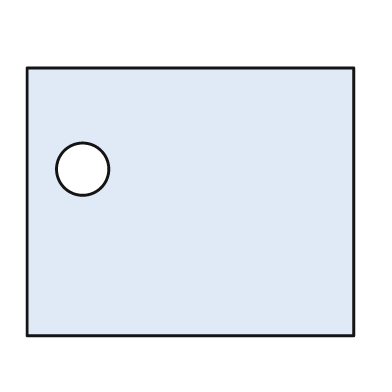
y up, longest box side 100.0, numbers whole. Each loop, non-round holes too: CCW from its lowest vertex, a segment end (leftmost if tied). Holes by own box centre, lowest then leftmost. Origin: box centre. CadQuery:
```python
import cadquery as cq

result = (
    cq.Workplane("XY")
    .moveTo(-50.0, -41.0)
    .lineTo(50.0, -41.0)
    .lineTo(50.0, 41.0)
    .lineTo(-50.0, 41.0)
    .close()
    .moveTo(-33.0, 10.0)
    .circle(8.0)
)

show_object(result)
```